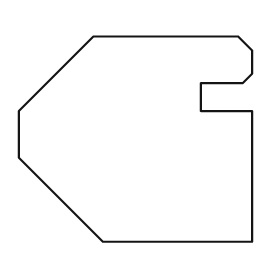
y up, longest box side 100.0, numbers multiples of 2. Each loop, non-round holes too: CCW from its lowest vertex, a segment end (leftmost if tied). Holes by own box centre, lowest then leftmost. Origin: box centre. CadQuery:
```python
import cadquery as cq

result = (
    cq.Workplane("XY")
    .moveTo(-14.0, -44.0)
    .lineTo(50.0, -44.0)
    .lineTo(50.0, 12.0)
    .lineTo(28.0, 12.0)
    .lineTo(28.0, 24.0)
    .lineTo(46.0, 24.0)
    .lineTo(50.0, 28.0)
    .lineTo(50.0, 38.0)
    .lineTo(44.0, 44.0)
    .lineTo(-18.0, 44.0)
    .lineTo(-50.0, 12.0)
    .lineTo(-50.0, -8.0)
    .close()
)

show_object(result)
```